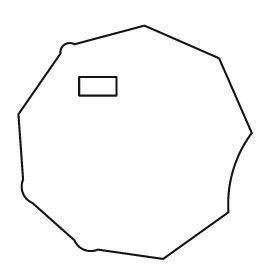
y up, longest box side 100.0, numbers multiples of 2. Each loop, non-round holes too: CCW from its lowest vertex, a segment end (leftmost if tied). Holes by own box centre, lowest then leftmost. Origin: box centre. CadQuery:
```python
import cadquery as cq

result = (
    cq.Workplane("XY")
    .moveTo(12.0, -50.0)
    .lineTo(40.0, -30.0)
    .threePointArc((42.0, -12.0), (50.0, 4.0))
    .lineTo(36.0, 36.0)
    .lineTo(4.0, 50.0)
    .lineTo(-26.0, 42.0)
    .threePointArc((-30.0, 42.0), (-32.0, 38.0))
    .lineTo(-50.0, 12.0)
    .lineTo(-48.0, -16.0)
    .threePointArc((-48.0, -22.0), (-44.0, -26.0))
    .lineTo(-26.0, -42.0)
    .threePointArc((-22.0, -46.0), (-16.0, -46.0))
    .close()
    .moveTo(-24.0, 20.0)
    .lineTo(-8.0, 20.0)
    .lineTo(-8.0, 28.0)
    .lineTo(-24.0, 28.0)
    .close()
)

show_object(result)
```